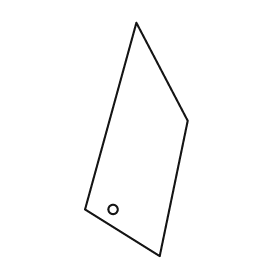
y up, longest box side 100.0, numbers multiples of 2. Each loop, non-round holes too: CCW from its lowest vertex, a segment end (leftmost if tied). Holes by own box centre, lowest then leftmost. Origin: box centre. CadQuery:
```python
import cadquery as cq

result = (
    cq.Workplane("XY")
    .moveTo(10.0, -50.0)
    .lineTo(22.0, 8.0)
    .lineTo(0.0, 50.0)
    .lineTo(-22.0, -30.0)
    .close()
    .moveTo(-10.0, -30.0)
    .circle(2.0)
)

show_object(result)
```